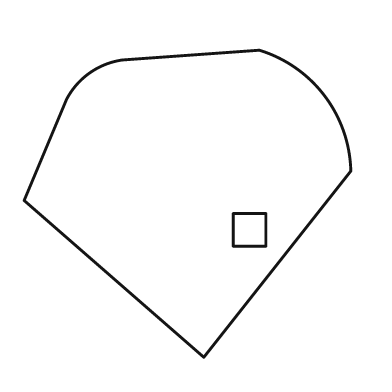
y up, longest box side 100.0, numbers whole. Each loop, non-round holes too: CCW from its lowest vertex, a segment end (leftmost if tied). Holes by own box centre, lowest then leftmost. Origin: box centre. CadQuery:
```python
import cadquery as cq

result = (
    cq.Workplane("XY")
    .moveTo(5.0, -47.0)
    .lineTo(50.0, 10.0)
    .threePointArc((42.0, 33.0), (22.0, 47.0))
    .lineTo(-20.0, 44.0)
    .threePointArc((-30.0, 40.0), (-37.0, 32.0))
    .lineTo(-50.0, 1.0)
    .close()
    .moveTo(14.0, -13.0)
    .lineTo(24.0, -13.0)
    .lineTo(24.0, -3.0)
    .lineTo(14.0, -3.0)
    .close()
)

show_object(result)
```